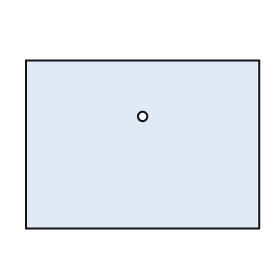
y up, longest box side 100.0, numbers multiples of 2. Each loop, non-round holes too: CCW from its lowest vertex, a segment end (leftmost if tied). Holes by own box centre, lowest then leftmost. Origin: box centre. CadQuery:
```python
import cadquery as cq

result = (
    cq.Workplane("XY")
    .moveTo(-50.0, -36.0)
    .lineTo(50.0, -36.0)
    .lineTo(50.0, 36.0)
    .lineTo(-50.0, 36.0)
    .close()
    .moveTo(0.0, 12.0)
    .circle(2.0)
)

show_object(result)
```